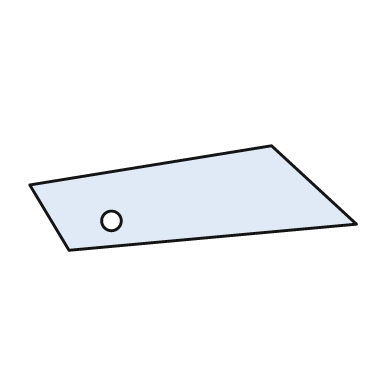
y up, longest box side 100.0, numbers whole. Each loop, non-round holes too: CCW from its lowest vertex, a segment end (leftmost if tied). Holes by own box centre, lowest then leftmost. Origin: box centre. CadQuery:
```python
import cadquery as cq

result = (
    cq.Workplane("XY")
    .moveTo(-38.0, -16.0)
    .lineTo(50.0, -8.0)
    .lineTo(24.0, 16.0)
    .lineTo(-50.0, 4.0)
    .close()
    .moveTo(-25.0, -7.0)
    .circle(3.0)
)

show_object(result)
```